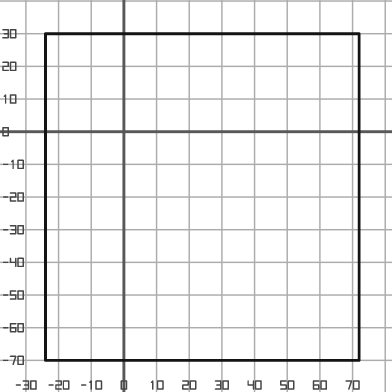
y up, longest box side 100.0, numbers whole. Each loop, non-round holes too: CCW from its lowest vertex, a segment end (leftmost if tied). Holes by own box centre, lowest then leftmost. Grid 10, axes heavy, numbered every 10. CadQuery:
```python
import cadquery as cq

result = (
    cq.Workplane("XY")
    .moveTo(-24.0, -70.0)
    .lineTo(72.0, -70.0)
    .lineTo(72.0, 30.0)
    .lineTo(-24.0, 30.0)
    .close()
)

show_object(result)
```